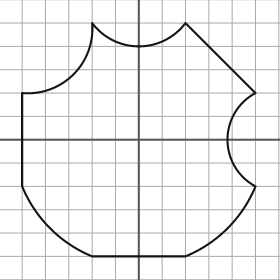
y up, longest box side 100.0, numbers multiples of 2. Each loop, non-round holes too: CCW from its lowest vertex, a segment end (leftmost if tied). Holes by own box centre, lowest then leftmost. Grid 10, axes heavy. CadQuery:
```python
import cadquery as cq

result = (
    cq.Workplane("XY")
    .moveTo(-20.0, -50.0)
    .lineTo(20.0, -50.0)
    .threePointArc((38.0, -38.0), (50.0, -20.0))
    .threePointArc((38.0, 0.0), (50.0, 20.0))
    .lineTo(20.0, 50.0)
    .threePointArc((0.0, 40.0), (-20.0, 50.0))
    .threePointArc((-28.0, 28.0), (-50.0, 20.0))
    .lineTo(-50.0, -20.0)
    .threePointArc((-38.0, -38.0), (-20.0, -50.0))
    .close()
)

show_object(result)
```